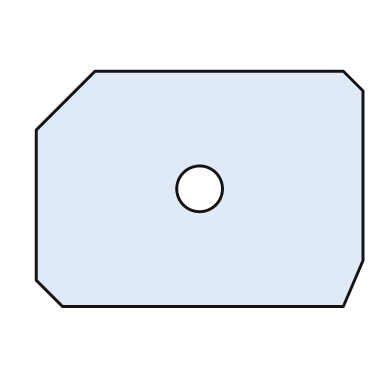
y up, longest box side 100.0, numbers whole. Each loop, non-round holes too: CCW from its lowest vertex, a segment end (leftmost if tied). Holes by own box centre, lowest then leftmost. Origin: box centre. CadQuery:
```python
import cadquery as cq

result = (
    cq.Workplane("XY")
    .moveTo(-42.0, -36.0)
    .lineTo(44.0, -36.0)
    .lineTo(50.0, -22.0)
    .lineTo(50.0, 30.0)
    .lineTo(44.0, 36.0)
    .lineTo(-32.0, 36.0)
    .lineTo(-50.0, 18.0)
    .lineTo(-50.0, -28.0)
    .close()
    .moveTo(0.0, 0.0)
    .circle(7.0)
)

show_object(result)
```